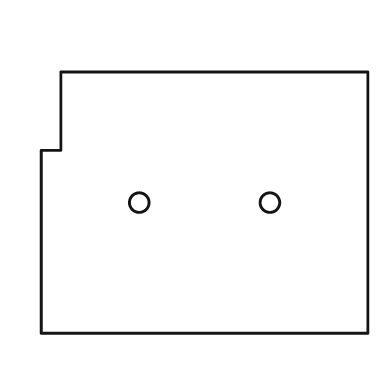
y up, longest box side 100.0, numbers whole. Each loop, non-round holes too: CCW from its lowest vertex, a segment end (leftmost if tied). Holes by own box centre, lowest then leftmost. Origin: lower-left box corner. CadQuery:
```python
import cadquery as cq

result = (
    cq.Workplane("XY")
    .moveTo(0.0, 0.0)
    .lineTo(100.0, 0.0)
    .lineTo(100.0, 80.0)
    .lineTo(6.0, 80.0)
    .lineTo(6.0, 56.0)
    .lineTo(0.0, 56.0)
    .close()
    .moveTo(30.0, 40.0)
    .circle(3.0)
    .moveTo(70.0, 40.0)
    .circle(3.0)
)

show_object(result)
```